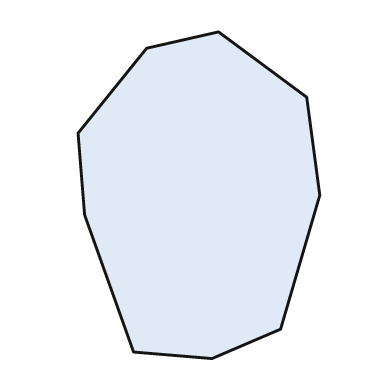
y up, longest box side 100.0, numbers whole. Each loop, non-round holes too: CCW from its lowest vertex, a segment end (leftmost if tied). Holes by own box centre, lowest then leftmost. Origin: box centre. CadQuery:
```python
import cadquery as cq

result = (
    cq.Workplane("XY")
    .moveTo(4.0, -50.0)
    .lineTo(25.0, -41.0)
    .lineTo(37.0, 0.0)
    .lineTo(33.0, 30.0)
    .lineTo(6.0, 50.0)
    .lineTo(-16.0, 45.0)
    .lineTo(-37.0, 19.0)
    .lineTo(-35.0, -6.0)
    .lineTo(-20.0, -48.0)
    .close()
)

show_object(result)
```